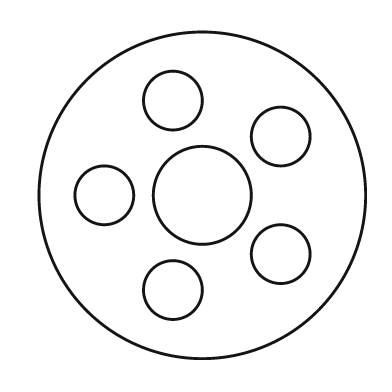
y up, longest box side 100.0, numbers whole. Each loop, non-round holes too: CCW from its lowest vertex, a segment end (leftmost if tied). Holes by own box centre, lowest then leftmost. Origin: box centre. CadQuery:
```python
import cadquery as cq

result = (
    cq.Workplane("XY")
    .moveTo(0.0, 0.0)
    .circle(50.0)
    .moveTo(-9.0, -29.0)
    .circle(9.0)
    .moveTo(24.0, -18.0)
    .circle(9.0)
    .moveTo(-30.0, 0.0)
    .circle(9.0)
    .moveTo(0.0, 0.0)
    .circle(15.0)
    .moveTo(24.0, 18.0)
    .circle(9.0)
    .moveTo(-9.0, 29.0)
    .circle(9.0)
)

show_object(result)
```